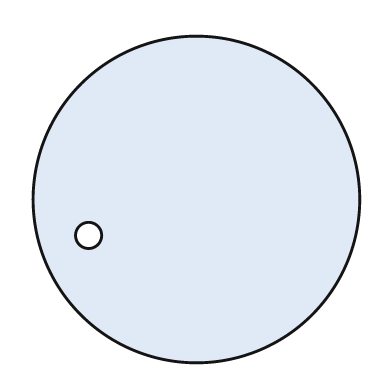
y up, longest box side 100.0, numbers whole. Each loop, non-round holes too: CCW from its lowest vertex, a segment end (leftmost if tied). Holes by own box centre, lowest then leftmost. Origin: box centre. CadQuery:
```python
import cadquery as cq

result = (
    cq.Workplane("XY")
    .moveTo(0.0, 0.0)
    .circle(50.0)
    .moveTo(-33.0, -11.0)
    .circle(4.0)
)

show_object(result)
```